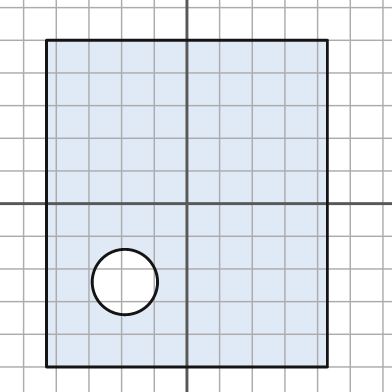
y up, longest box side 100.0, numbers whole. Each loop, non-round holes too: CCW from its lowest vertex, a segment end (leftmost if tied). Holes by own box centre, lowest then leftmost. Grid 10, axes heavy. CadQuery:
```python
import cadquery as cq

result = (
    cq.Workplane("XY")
    .moveTo(-43.0, -50.0)
    .lineTo(43.0, -50.0)
    .lineTo(43.0, 50.0)
    .lineTo(-43.0, 50.0)
    .close()
    .moveTo(-19.0, -24.0)
    .circle(10.0)
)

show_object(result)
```